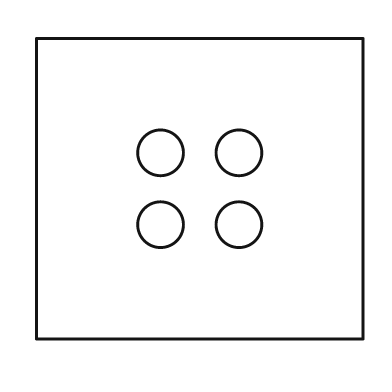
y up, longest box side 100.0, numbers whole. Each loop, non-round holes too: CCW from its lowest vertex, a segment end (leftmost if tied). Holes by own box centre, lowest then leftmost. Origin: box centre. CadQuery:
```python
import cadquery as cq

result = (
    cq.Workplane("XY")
    .moveTo(-50.0, -46.0)
    .lineTo(50.0, -46.0)
    .lineTo(50.0, 46.0)
    .lineTo(-50.0, 46.0)
    .close()
    .moveTo(-12.0, -11.0)
    .circle(7.0)
    .moveTo(12.0, -11.0)
    .circle(7.0)
    .moveTo(-12.0, 11.0)
    .circle(7.0)
    .moveTo(12.0, 11.0)
    .circle(7.0)
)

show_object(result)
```